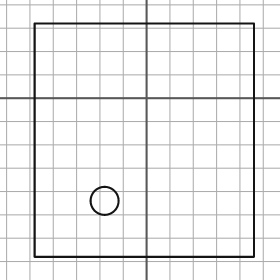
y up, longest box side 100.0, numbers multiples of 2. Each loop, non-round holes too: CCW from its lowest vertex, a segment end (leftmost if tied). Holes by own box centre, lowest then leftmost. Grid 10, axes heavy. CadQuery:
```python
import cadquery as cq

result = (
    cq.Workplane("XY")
    .moveTo(-48.0, -68.0)
    .lineTo(46.0, -68.0)
    .lineTo(46.0, 32.0)
    .lineTo(-48.0, 32.0)
    .close()
    .moveTo(-18.0, -44.0)
    .circle(6.0)
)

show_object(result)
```